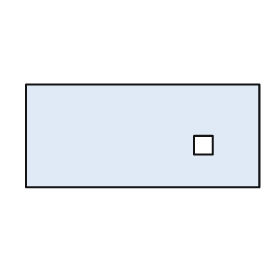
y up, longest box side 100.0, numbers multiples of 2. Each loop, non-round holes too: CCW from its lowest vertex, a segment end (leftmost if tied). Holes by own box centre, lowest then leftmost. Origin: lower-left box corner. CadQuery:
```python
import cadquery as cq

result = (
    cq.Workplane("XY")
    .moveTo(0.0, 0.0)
    .lineTo(100.0, 0.0)
    .lineTo(100.0, 44.0)
    .lineTo(0.0, 44.0)
    .close()
    .moveTo(72.0, 14.0)
    .lineTo(80.0, 14.0)
    .lineTo(80.0, 22.0)
    .lineTo(72.0, 22.0)
    .close()
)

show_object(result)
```